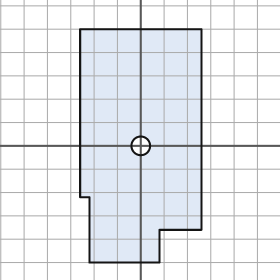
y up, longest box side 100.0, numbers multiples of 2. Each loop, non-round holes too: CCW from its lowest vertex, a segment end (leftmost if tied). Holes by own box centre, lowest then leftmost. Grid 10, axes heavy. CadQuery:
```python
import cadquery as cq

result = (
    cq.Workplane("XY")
    .moveTo(-22.0, -50.0)
    .lineTo(8.0, -50.0)
    .lineTo(8.0, -36.0)
    .lineTo(26.0, -36.0)
    .lineTo(26.0, 50.0)
    .lineTo(-26.0, 50.0)
    .lineTo(-26.0, -22.0)
    .lineTo(-22.0, -22.0)
    .close()
    .moveTo(0.0, 0.0)
    .circle(4.0)
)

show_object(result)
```